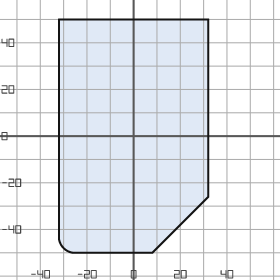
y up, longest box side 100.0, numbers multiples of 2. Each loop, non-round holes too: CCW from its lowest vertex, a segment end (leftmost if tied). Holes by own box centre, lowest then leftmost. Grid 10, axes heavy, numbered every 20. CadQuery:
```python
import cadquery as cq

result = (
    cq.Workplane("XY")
    .moveTo(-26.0, -50.0)
    .lineTo(8.0, -50.0)
    .lineTo(32.0, -26.0)
    .lineTo(32.0, 50.0)
    .lineTo(-32.0, 50.0)
    .lineTo(-32.0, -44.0)
    .threePointArc((-30.0, -48.0), (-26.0, -50.0))
    .close()
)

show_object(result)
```